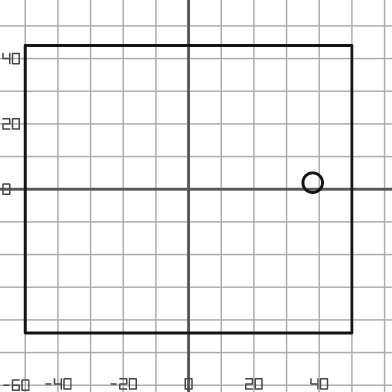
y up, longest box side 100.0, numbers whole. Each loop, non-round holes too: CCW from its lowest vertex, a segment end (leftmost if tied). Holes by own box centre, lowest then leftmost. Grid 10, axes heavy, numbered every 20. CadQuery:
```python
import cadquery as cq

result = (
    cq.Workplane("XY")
    .moveTo(-50.0, -44.0)
    .lineTo(50.0, -44.0)
    .lineTo(50.0, 44.0)
    .lineTo(-50.0, 44.0)
    .close()
    .moveTo(38.0, 2.0)
    .circle(3.0)
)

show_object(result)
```